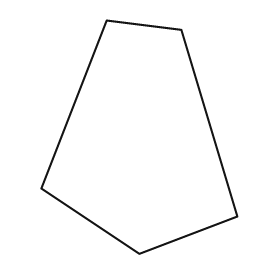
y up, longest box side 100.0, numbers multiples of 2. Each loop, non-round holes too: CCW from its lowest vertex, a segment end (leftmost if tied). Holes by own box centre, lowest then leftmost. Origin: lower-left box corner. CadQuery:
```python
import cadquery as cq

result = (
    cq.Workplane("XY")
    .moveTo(42.0, 0.0)
    .lineTo(84.0, 16.0)
    .lineTo(60.0, 96.0)
    .lineTo(28.0, 100.0)
    .lineTo(0.0, 28.0)
    .close()
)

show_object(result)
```